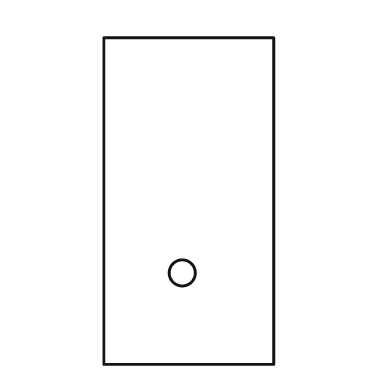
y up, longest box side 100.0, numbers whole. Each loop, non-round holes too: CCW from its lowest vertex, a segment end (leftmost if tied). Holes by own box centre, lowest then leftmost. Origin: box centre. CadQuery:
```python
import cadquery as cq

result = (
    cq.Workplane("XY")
    .moveTo(-26.0, -50.0)
    .lineTo(26.0, -50.0)
    .lineTo(26.0, 50.0)
    .lineTo(-26.0, 50.0)
    .close()
    .moveTo(-2.0, -22.0)
    .circle(4.0)
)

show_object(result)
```